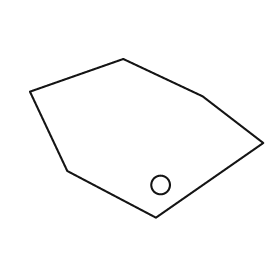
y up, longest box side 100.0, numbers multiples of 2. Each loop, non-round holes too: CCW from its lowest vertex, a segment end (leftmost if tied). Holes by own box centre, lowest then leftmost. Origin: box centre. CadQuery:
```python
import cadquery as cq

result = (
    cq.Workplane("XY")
    .moveTo(4.0, -34.0)
    .lineTo(50.0, -2.0)
    .lineTo(24.0, 18.0)
    .lineTo(-10.0, 34.0)
    .lineTo(-50.0, 20.0)
    .lineTo(-34.0, -14.0)
    .close()
    .moveTo(6.0, -20.0)
    .circle(4.0)
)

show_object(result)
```